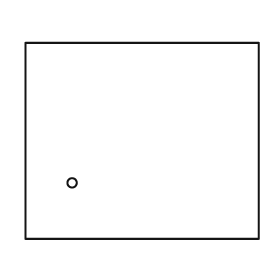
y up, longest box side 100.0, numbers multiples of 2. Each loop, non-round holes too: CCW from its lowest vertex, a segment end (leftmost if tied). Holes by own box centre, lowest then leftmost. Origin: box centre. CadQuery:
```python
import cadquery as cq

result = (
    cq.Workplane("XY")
    .moveTo(-50.0, -42.0)
    .lineTo(50.0, -42.0)
    .lineTo(50.0, 42.0)
    .lineTo(-50.0, 42.0)
    .close()
    .moveTo(-30.0, -18.0)
    .circle(2.0)
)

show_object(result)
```